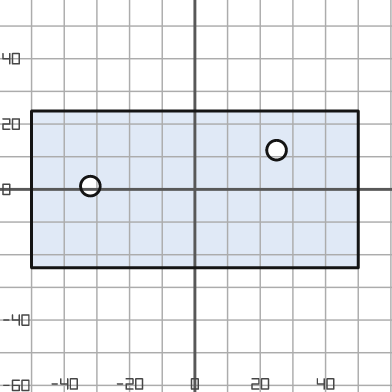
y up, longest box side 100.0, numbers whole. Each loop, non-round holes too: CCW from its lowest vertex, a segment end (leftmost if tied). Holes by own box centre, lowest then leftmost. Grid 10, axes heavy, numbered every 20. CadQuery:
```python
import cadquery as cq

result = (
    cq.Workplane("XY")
    .moveTo(-50.0, -24.0)
    .lineTo(50.0, -24.0)
    .lineTo(50.0, 24.0)
    .lineTo(-50.0, 24.0)
    .close()
    .moveTo(-32.0, 1.0)
    .circle(3.0)
    .moveTo(25.0, 12.0)
    .circle(3.0)
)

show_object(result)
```